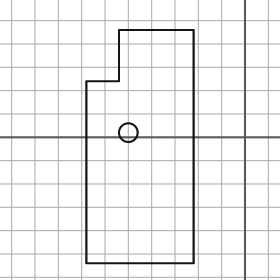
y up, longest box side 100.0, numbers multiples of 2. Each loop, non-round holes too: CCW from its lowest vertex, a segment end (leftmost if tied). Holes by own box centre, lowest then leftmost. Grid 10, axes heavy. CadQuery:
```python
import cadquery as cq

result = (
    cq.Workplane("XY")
    .moveTo(-68.0, -54.0)
    .lineTo(-22.0, -54.0)
    .lineTo(-22.0, 46.0)
    .lineTo(-54.0, 46.0)
    .lineTo(-54.0, 24.0)
    .lineTo(-68.0, 24.0)
    .close()
    .moveTo(-50.0, 2.0)
    .circle(4.0)
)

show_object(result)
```